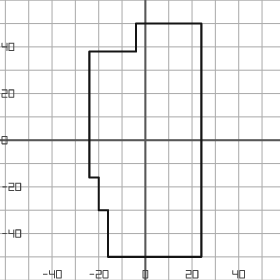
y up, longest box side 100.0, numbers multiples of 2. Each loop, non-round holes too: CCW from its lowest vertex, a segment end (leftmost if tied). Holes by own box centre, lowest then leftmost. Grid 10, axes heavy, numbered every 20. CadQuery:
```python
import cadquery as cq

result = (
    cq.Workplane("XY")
    .moveTo(-16.0, -50.0)
    .lineTo(24.0, -50.0)
    .lineTo(24.0, 50.0)
    .lineTo(-4.0, 50.0)
    .lineTo(-4.0, 38.0)
    .lineTo(-24.0, 38.0)
    .lineTo(-24.0, -16.0)
    .lineTo(-20.0, -16.0)
    .lineTo(-20.0, -30.0)
    .lineTo(-16.0, -30.0)
    .close()
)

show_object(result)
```